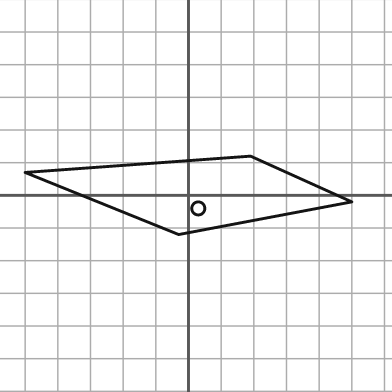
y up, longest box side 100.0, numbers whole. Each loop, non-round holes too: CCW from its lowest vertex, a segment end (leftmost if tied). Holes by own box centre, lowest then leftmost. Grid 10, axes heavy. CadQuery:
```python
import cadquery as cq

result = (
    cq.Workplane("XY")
    .moveTo(-3.0, -12.0)
    .lineTo(50.0, -2.0)
    .lineTo(19.0, 12.0)
    .lineTo(-50.0, 7.0)
    .close()
    .moveTo(3.0, -4.0)
    .circle(2.0)
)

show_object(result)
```